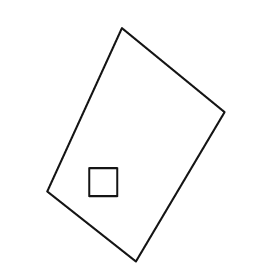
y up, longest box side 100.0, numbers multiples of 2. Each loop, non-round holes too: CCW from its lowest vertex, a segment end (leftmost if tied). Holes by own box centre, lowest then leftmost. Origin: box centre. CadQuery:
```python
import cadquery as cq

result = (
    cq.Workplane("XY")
    .moveTo(0.0, -50.0)
    .lineTo(38.0, 14.0)
    .lineTo(-6.0, 50.0)
    .lineTo(-38.0, -20.0)
    .close()
    .moveTo(-20.0, -22.0)
    .lineTo(-8.0, -22.0)
    .lineTo(-8.0, -10.0)
    .lineTo(-20.0, -10.0)
    .close()
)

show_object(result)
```